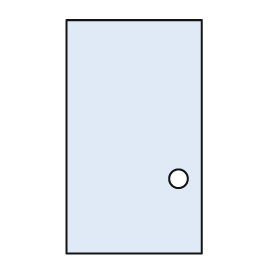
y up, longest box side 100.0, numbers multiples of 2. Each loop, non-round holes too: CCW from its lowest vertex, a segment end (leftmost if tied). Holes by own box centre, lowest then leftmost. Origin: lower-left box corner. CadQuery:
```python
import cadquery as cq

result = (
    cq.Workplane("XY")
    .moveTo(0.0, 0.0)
    .lineTo(58.0, 0.0)
    .lineTo(58.0, 100.0)
    .lineTo(0.0, 100.0)
    .close()
    .moveTo(48.0, 32.0)
    .circle(4.0)
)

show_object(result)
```